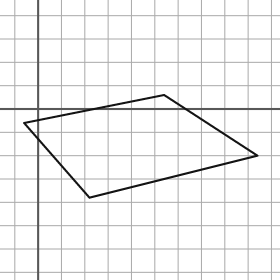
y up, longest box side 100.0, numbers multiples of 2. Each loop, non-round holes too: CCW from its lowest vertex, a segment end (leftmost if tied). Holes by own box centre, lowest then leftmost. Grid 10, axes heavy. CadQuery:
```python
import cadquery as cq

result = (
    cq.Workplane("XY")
    .moveTo(22.0, -38.0)
    .lineTo(94.0, -20.0)
    .lineTo(54.0, 6.0)
    .lineTo(-6.0, -6.0)
    .close()
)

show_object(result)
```